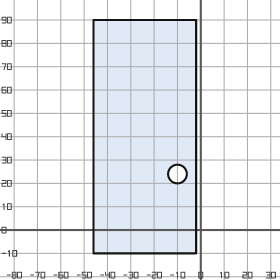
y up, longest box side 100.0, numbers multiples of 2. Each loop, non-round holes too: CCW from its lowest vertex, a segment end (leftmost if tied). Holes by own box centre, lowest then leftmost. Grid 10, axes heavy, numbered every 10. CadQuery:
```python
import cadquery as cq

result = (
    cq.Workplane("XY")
    .moveTo(-46.0, -10.0)
    .lineTo(-2.0, -10.0)
    .lineTo(-2.0, 90.0)
    .lineTo(-46.0, 90.0)
    .close()
    .moveTo(-10.0, 24.0)
    .circle(4.0)
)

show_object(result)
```